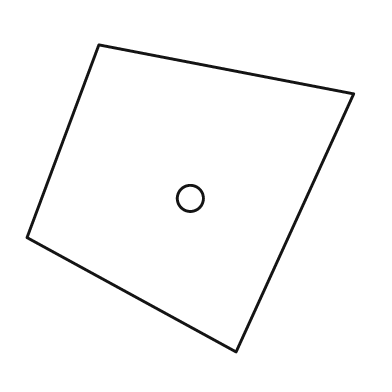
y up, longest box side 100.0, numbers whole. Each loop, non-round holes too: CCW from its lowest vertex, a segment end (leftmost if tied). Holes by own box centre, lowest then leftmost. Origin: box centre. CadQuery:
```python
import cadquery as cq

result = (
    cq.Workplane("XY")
    .moveTo(14.0, -47.0)
    .lineTo(50.0, 32.0)
    .lineTo(-28.0, 47.0)
    .lineTo(-50.0, -12.0)
    .close()
    .moveTo(0.0, 0.0)
    .circle(4.0)
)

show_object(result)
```